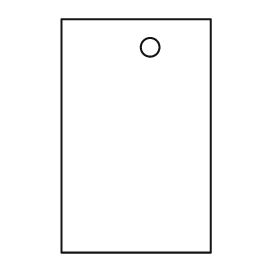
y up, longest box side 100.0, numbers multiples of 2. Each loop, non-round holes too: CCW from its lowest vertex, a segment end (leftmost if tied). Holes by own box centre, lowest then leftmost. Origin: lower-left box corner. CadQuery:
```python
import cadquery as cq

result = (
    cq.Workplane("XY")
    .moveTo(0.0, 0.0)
    .lineTo(64.0, 0.0)
    .lineTo(64.0, 100.0)
    .lineTo(0.0, 100.0)
    .close()
    .moveTo(38.0, 88.0)
    .circle(4.0)
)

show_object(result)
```